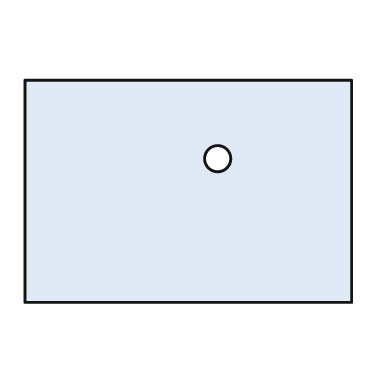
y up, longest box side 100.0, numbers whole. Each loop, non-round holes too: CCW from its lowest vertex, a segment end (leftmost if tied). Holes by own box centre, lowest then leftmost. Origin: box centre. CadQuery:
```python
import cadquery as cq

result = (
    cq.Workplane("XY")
    .moveTo(-50.0, -34.0)
    .lineTo(50.0, -34.0)
    .lineTo(50.0, 34.0)
    .lineTo(-50.0, 34.0)
    .close()
    .moveTo(9.0, 10.0)
    .circle(4.0)
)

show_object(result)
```